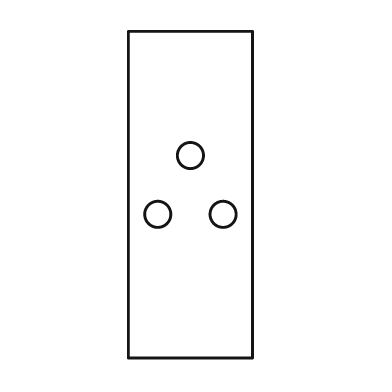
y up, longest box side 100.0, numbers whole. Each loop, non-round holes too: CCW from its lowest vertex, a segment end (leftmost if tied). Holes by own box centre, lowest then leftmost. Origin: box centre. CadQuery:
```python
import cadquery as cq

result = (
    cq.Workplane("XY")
    .moveTo(-19.0, -50.0)
    .lineTo(19.0, -50.0)
    .lineTo(19.0, 50.0)
    .lineTo(-19.0, 50.0)
    .close()
    .moveTo(-10.0, -6.0)
    .circle(4.0)
    .moveTo(10.0, -6.0)
    .circle(4.0)
    .moveTo(0.0, 12.0)
    .circle(4.0)
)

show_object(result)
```